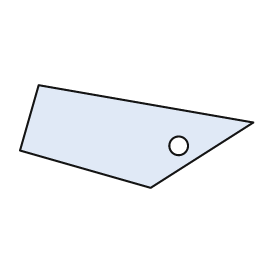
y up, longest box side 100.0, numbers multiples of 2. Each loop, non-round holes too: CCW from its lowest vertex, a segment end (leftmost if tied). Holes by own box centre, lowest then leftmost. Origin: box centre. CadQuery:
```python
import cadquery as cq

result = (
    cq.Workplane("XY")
    .moveTo(6.0, -22.0)
    .lineTo(50.0, 6.0)
    .lineTo(-42.0, 22.0)
    .lineTo(-50.0, -6.0)
    .close()
    .moveTo(18.0, -4.0)
    .circle(4.0)
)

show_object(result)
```